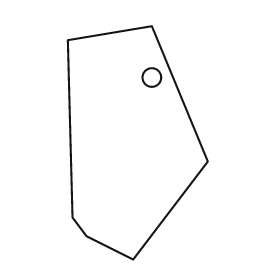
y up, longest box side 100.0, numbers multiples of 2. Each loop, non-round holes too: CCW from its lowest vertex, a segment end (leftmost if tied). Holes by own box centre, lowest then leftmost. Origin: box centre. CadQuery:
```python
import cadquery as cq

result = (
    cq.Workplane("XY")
    .moveTo(-2.0, -50.0)
    .lineTo(30.0, -8.0)
    .lineTo(6.0, 50.0)
    .lineTo(-30.0, 44.0)
    .lineTo(-28.0, -32.0)
    .lineTo(-22.0, -40.0)
    .close()
    .moveTo(6.0, 28.0)
    .circle(4.0)
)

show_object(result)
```